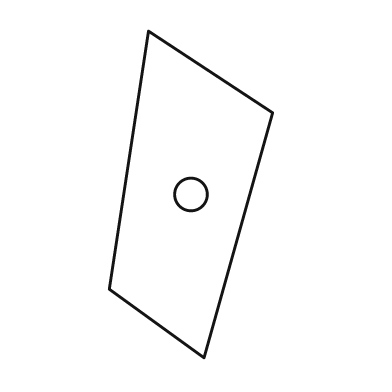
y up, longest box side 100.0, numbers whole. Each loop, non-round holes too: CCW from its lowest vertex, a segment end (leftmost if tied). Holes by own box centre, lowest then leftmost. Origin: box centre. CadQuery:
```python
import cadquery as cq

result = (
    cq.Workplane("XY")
    .moveTo(4.0, -50.0)
    .lineTo(25.0, 25.0)
    .lineTo(-13.0, 50.0)
    .lineTo(-25.0, -29.0)
    .close()
    .moveTo(0.0, 0.0)
    .circle(5.0)
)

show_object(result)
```